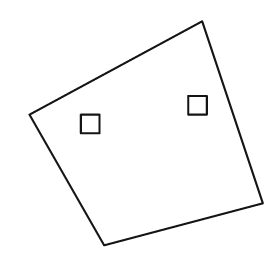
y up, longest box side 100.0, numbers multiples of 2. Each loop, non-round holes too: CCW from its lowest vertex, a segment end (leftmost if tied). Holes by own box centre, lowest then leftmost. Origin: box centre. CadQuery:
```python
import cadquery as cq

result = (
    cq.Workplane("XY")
    .moveTo(-18.0, -48.0)
    .lineTo(50.0, -30.0)
    .lineTo(24.0, 48.0)
    .lineTo(-50.0, 8.0)
    .close()
    .moveTo(-28.0, 0.0)
    .lineTo(-20.0, 0.0)
    .lineTo(-20.0, 8.0)
    .lineTo(-28.0, 8.0)
    .close()
    .moveTo(18.0, 8.0)
    .lineTo(26.0, 8.0)
    .lineTo(26.0, 16.0)
    .lineTo(18.0, 16.0)
    .close()
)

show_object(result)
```